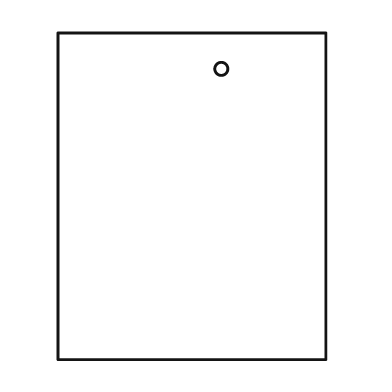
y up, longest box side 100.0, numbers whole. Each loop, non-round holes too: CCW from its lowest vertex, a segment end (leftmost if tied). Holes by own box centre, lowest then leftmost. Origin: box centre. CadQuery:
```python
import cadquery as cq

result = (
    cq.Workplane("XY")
    .moveTo(-41.0, -50.0)
    .lineTo(41.0, -50.0)
    .lineTo(41.0, 50.0)
    .lineTo(-41.0, 50.0)
    .close()
    .moveTo(9.0, 39.0)
    .circle(2.0)
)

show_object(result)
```